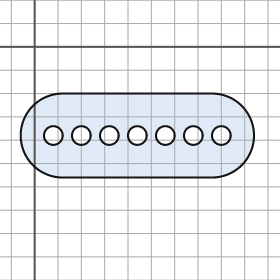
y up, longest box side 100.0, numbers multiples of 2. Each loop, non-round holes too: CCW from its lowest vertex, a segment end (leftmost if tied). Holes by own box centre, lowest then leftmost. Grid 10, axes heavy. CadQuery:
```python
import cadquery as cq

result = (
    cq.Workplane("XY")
    .moveTo(12.0, -56.0)
    .lineTo(76.0, -56.0)
    .threePointArc((94.0, -38.0), (76.0, -20.0))
    .lineTo(12.0, -20.0)
    .threePointArc((-6.0, -38.0), (12.0, -56.0))
    .close()
    .moveTo(8.0, -38.0)
    .circle(4.0)
    .moveTo(20.0, -38.0)
    .circle(4.0)
    .moveTo(32.0, -38.0)
    .circle(4.0)
    .moveTo(44.0, -38.0)
    .circle(4.0)
    .moveTo(56.0, -38.0)
    .circle(4.0)
    .moveTo(68.0, -38.0)
    .circle(4.0)
    .moveTo(80.0, -38.0)
    .circle(4.0)
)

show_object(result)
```